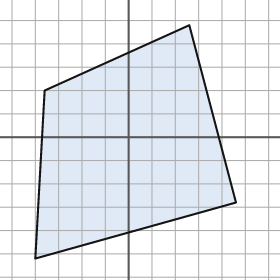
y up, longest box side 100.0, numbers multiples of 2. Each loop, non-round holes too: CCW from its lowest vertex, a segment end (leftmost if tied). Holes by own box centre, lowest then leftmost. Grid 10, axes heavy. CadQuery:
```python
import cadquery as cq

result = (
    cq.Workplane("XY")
    .moveTo(-40.0, -52.0)
    .lineTo(46.0, -28.0)
    .lineTo(26.0, 48.0)
    .lineTo(-36.0, 20.0)
    .close()
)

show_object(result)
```